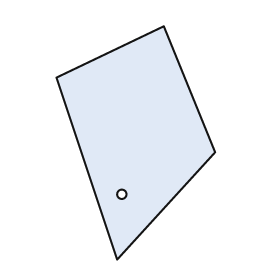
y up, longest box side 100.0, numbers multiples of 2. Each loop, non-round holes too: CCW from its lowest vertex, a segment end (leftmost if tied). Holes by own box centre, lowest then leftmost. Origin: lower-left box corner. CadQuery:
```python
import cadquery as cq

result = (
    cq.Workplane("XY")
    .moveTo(26.0, 0.0)
    .lineTo(68.0, 46.0)
    .lineTo(46.0, 100.0)
    .lineTo(0.0, 78.0)
    .close()
    .moveTo(28.0, 28.0)
    .circle(2.0)
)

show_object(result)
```